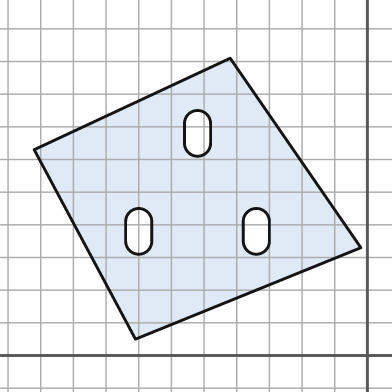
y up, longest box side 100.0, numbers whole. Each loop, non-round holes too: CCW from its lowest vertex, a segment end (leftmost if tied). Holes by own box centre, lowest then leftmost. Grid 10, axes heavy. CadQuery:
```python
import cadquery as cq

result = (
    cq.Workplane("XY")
    .moveTo(-71.0, 5.0)
    .lineTo(-2.0, 33.0)
    .lineTo(-42.0, 91.0)
    .lineTo(-102.0, 63.0)
    .close()
    .moveTo(-74.0, 35.0)
    .threePointArc((-70.0, 31.0), (-66.0, 35.0))
    .lineTo(-66.0, 41.0)
    .threePointArc((-70.0, 45.0), (-74.0, 41.0))
    .close()
    .moveTo(-38.0, 35.0)
    .threePointArc((-34.0, 31.0), (-30.0, 35.0))
    .lineTo(-30.0, 41.0)
    .threePointArc((-34.0, 45.0), (-38.0, 41.0))
    .close()
    .moveTo(-56.0, 65.0)
    .threePointArc((-52.0, 61.0), (-48.0, 65.0))
    .lineTo(-48.0, 71.0)
    .threePointArc((-52.0, 75.0), (-56.0, 71.0))
    .close()
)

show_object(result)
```